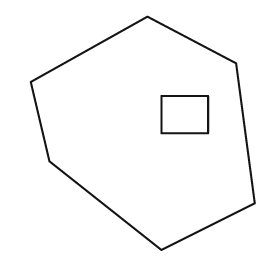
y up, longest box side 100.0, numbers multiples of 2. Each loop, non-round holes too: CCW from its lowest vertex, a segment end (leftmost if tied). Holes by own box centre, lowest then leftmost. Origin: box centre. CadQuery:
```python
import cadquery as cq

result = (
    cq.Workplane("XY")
    .moveTo(8.0, -50.0)
    .lineTo(48.0, -30.0)
    .lineTo(40.0, 30.0)
    .lineTo(2.0, 50.0)
    .lineTo(-48.0, 22.0)
    .lineTo(-40.0, -12.0)
    .close()
    .moveTo(8.0, 0.0)
    .lineTo(28.0, 0.0)
    .lineTo(28.0, 16.0)
    .lineTo(8.0, 16.0)
    .close()
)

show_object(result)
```